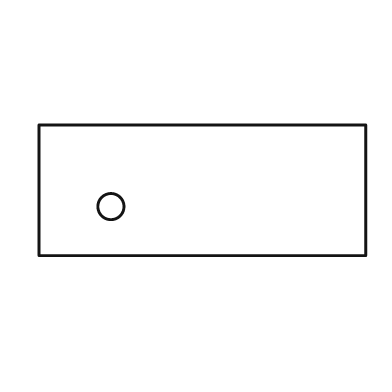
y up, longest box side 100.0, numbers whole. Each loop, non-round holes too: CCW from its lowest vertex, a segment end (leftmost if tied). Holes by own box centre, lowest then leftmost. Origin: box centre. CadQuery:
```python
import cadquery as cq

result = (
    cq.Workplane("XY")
    .moveTo(-50.0, -20.0)
    .lineTo(50.0, -20.0)
    .lineTo(50.0, 20.0)
    .lineTo(-50.0, 20.0)
    .close()
    .moveTo(-28.0, -5.0)
    .circle(4.0)
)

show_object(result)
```